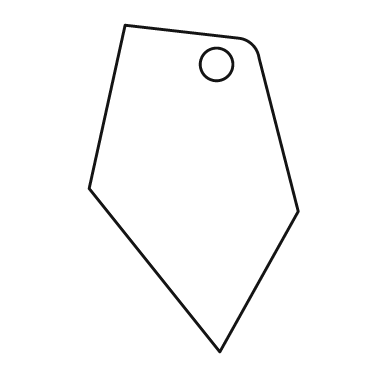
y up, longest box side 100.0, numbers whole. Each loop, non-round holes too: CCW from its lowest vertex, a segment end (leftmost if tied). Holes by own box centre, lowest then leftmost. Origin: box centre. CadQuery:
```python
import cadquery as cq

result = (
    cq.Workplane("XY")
    .moveTo(8.0, -50.0)
    .lineTo(32.0, -7.0)
    .lineTo(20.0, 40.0)
    .threePointArc((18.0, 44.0), (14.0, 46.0))
    .lineTo(-21.0, 50.0)
    .lineTo(-32.0, 0.0)
    .close()
    .moveTo(7.0, 38.0)
    .circle(5.0)
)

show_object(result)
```